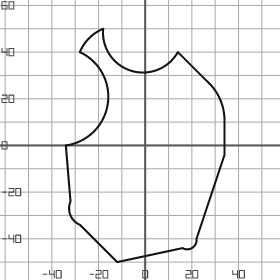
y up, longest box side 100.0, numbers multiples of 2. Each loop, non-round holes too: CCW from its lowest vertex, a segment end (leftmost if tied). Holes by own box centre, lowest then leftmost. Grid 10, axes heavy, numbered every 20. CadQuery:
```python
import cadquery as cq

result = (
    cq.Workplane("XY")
    .moveTo(-12.0, -50.0)
    .lineTo(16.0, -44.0)
    .threePointArc((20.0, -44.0), (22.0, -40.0))
    .lineTo(34.0, -4.0)
    .lineTo(34.0, 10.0)
    .threePointArc((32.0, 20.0), (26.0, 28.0))
    .lineTo(14.0, 40.0)
    .threePointArc((-6.0, 32.0), (-18.0, 50.0))
    .threePointArc((-24.0, 46.0), (-28.0, 40.0))
    .threePointArc((-16.0, 18.0), (-34.0, 0.0))
    .lineTo(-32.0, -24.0)
    .threePointArc((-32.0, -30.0), (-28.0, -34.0))
    .close()
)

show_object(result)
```